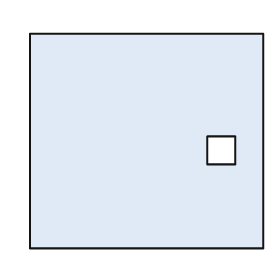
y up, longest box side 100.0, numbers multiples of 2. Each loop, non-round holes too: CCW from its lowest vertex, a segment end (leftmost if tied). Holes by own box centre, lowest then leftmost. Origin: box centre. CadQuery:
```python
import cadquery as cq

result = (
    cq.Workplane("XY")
    .moveTo(-50.0, -46.0)
    .lineTo(50.0, -46.0)
    .lineTo(50.0, 46.0)
    .lineTo(-50.0, 46.0)
    .close()
    .moveTo(26.0, -10.0)
    .lineTo(38.0, -10.0)
    .lineTo(38.0, 2.0)
    .lineTo(26.0, 2.0)
    .close()
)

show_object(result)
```